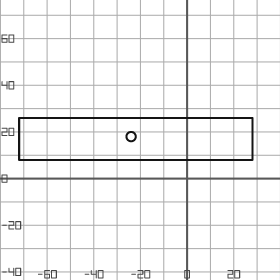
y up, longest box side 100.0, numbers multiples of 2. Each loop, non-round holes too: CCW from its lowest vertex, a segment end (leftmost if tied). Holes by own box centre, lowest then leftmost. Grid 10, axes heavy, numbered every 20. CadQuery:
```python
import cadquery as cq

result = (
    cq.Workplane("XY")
    .moveTo(-72.0, 8.0)
    .lineTo(28.0, 8.0)
    .lineTo(28.0, 26.0)
    .lineTo(-72.0, 26.0)
    .close()
    .moveTo(-24.0, 18.0)
    .circle(2.0)
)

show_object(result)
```